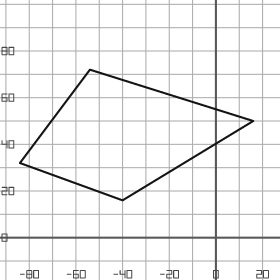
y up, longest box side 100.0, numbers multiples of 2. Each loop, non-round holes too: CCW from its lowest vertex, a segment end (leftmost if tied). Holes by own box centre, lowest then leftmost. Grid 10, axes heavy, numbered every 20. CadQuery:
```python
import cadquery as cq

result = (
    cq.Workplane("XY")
    .moveTo(-40.0, 16.0)
    .lineTo(16.0, 50.0)
    .lineTo(-54.0, 72.0)
    .lineTo(-84.0, 32.0)
    .close()
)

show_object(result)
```